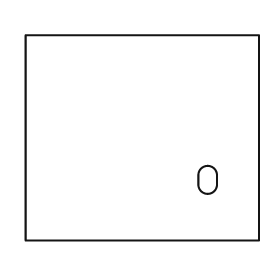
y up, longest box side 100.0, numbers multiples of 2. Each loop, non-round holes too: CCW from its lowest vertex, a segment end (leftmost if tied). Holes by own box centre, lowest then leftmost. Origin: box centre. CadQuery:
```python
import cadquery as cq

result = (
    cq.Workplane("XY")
    .moveTo(-50.0, -44.0)
    .lineTo(50.0, -44.0)
    .lineTo(50.0, 44.0)
    .lineTo(-50.0, 44.0)
    .close()
    .moveTo(24.0, -20.0)
    .threePointArc((28.0, -24.0), (32.0, -20.0))
    .lineTo(32.0, -16.0)
    .threePointArc((28.0, -12.0), (24.0, -16.0))
    .close()
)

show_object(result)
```